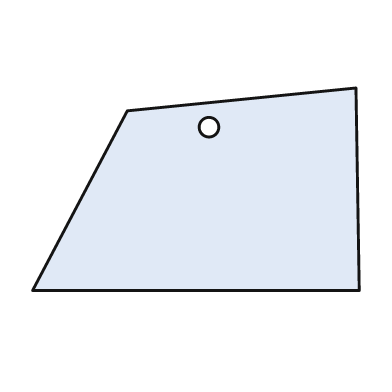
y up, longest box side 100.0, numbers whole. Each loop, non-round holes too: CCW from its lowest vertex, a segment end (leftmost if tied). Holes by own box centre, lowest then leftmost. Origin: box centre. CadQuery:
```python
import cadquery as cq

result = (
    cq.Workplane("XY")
    .moveTo(-50.0, -31.0)
    .lineTo(50.0, -31.0)
    .lineTo(49.0, 31.0)
    .lineTo(-21.0, 24.0)
    .close()
    .moveTo(4.0, 19.0)
    .circle(3.0)
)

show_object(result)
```